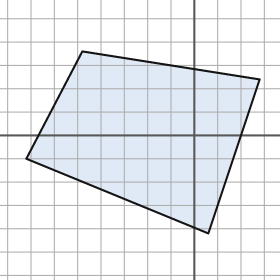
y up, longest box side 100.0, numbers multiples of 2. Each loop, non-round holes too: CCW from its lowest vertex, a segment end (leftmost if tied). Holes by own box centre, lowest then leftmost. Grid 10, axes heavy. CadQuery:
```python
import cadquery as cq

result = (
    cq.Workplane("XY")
    .moveTo(6.0, -42.0)
    .lineTo(28.0, 24.0)
    .lineTo(-48.0, 36.0)
    .lineTo(-72.0, -10.0)
    .close()
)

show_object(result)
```